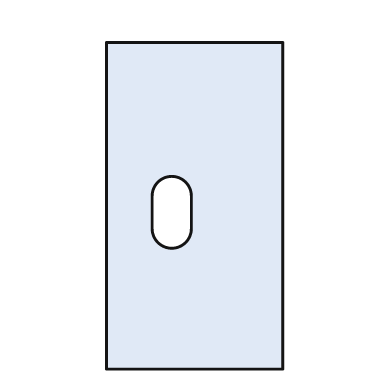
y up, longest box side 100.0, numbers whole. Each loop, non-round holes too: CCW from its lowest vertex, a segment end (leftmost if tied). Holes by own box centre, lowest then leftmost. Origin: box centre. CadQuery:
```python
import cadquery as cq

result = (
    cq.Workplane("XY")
    .moveTo(-27.0, -50.0)
    .lineTo(27.0, -50.0)
    .lineTo(27.0, 50.0)
    .lineTo(-27.0, 50.0)
    .close()
    .moveTo(-13.0, -7.0)
    .threePointArc((-7.0, -13.0), (-1.0, -7.0))
    .lineTo(-1.0, 3.0)
    .threePointArc((-7.0, 9.0), (-13.0, 3.0))
    .close()
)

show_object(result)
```